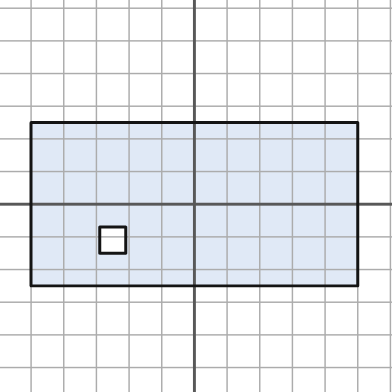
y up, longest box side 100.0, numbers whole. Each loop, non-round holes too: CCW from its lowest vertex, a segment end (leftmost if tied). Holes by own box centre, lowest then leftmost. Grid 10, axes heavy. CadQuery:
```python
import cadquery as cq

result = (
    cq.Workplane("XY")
    .moveTo(-50.0, -25.0)
    .lineTo(50.0, -25.0)
    .lineTo(50.0, 25.0)
    .lineTo(-50.0, 25.0)
    .close()
    .moveTo(-29.0, -15.0)
    .lineTo(-21.0, -15.0)
    .lineTo(-21.0, -7.0)
    .lineTo(-29.0, -7.0)
    .close()
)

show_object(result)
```